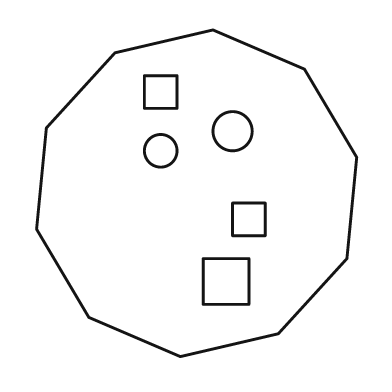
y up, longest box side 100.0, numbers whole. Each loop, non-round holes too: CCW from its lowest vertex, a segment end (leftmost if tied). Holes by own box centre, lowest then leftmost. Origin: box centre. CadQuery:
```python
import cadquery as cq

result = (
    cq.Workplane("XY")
    .moveTo(-5.0, -50.0)
    .lineTo(25.0, -43.0)
    .lineTo(46.0, -20.0)
    .lineTo(49.0, 11.0)
    .lineTo(33.0, 38.0)
    .lineTo(5.0, 50.0)
    .lineTo(-25.0, 43.0)
    .lineTo(-46.0, 20.0)
    .lineTo(-49.0, -11.0)
    .lineTo(-33.0, -38.0)
    .close()
    .moveTo(2.0, -34.0)
    .lineTo(16.0, -34.0)
    .lineTo(16.0, -20.0)
    .lineTo(2.0, -20.0)
    .close()
    .moveTo(11.0, -13.0)
    .lineTo(21.0, -13.0)
    .lineTo(21.0, -3.0)
    .lineTo(11.0, -3.0)
    .close()
    .moveTo(-11.0, 13.0)
    .circle(5.0)
    .moveTo(11.0, 19.0)
    .circle(6.0)
    .moveTo(-16.0, 26.0)
    .lineTo(-6.0, 26.0)
    .lineTo(-6.0, 36.0)
    .lineTo(-16.0, 36.0)
    .close()
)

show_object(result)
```